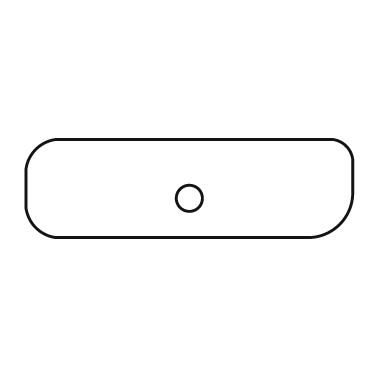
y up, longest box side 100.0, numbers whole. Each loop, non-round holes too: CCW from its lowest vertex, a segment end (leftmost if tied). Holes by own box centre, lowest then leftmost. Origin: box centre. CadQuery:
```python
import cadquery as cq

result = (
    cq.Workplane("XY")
    .moveTo(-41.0, -15.0)
    .lineTo(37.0, -15.0)
    .threePointArc((46.0, -11.0), (50.0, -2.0))
    .lineTo(50.0, 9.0)
    .threePointArc((48.0, 13.0), (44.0, 15.0))
    .lineTo(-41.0, 15.0)
    .threePointArc((-47.0, 12.0), (-50.0, 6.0))
    .lineTo(-50.0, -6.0)
    .threePointArc((-47.0, -12.0), (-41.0, -15.0))
    .close()
    .moveTo(0.0, -3.0)
    .circle(4.0)
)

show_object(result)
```